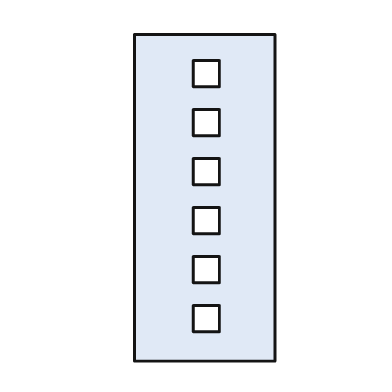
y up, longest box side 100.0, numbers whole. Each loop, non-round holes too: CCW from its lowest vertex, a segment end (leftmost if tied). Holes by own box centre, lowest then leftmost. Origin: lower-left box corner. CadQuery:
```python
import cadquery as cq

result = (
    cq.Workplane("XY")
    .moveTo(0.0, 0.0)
    .lineTo(43.0, 0.0)
    .lineTo(43.0, 100.0)
    .lineTo(0.0, 100.0)
    .close()
    .moveTo(18.0, 9.0)
    .lineTo(26.0, 9.0)
    .lineTo(26.0, 17.0)
    .lineTo(18.0, 17.0)
    .close()
    .moveTo(18.0, 24.0)
    .lineTo(26.0, 24.0)
    .lineTo(26.0, 32.0)
    .lineTo(18.0, 32.0)
    .close()
    .moveTo(18.0, 39.0)
    .lineTo(26.0, 39.0)
    .lineTo(26.0, 47.0)
    .lineTo(18.0, 47.0)
    .close()
    .moveTo(18.0, 54.0)
    .lineTo(26.0, 54.0)
    .lineTo(26.0, 62.0)
    .lineTo(18.0, 62.0)
    .close()
    .moveTo(18.0, 69.0)
    .lineTo(26.0, 69.0)
    .lineTo(26.0, 77.0)
    .lineTo(18.0, 77.0)
    .close()
    .moveTo(18.0, 84.0)
    .lineTo(26.0, 84.0)
    .lineTo(26.0, 92.0)
    .lineTo(18.0, 92.0)
    .close()
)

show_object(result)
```